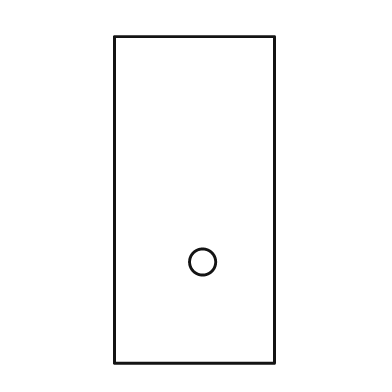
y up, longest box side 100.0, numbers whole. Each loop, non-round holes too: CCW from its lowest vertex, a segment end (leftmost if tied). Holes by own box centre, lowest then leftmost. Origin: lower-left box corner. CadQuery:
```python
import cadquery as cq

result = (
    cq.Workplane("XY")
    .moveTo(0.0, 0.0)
    .lineTo(49.0, 0.0)
    .lineTo(49.0, 100.0)
    .lineTo(0.0, 100.0)
    .close()
    .moveTo(27.0, 31.0)
    .circle(4.0)
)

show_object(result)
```